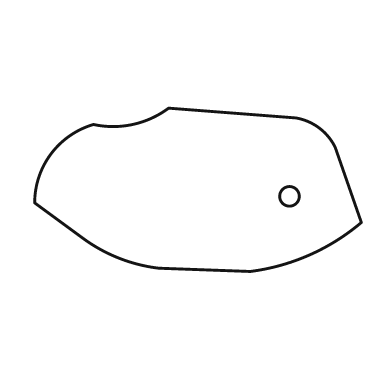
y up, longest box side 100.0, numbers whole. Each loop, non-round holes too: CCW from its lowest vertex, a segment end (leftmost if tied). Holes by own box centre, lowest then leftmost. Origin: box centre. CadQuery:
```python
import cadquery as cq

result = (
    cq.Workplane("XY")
    .moveTo(16.0, -25.0)
    .threePointArc((34.0, -20.0), (50.0, -10.0))
    .lineTo(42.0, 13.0)
    .threePointArc((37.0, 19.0), (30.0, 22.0))
    .lineTo(-9.0, 25.0)
    .threePointArc((-20.0, 20.0), (-32.0, 20.0))
    .threePointArc((-45.0, 11.0), (-50.0, -4.0))
    .lineTo(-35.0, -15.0)
    .threePointArc((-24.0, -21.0), (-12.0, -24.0))
    .close()
    .moveTo(28.0, -2.0)
    .circle(3.0)
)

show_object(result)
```